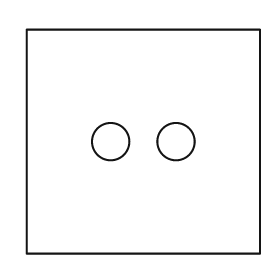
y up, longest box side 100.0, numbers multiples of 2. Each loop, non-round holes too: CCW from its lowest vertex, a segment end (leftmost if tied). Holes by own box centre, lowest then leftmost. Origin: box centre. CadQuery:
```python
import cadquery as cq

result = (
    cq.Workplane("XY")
    .moveTo(-50.0, -48.0)
    .lineTo(50.0, -48.0)
    .lineTo(50.0, 48.0)
    .lineTo(-50.0, 48.0)
    .close()
    .moveTo(-14.0, 0.0)
    .circle(8.0)
    .moveTo(14.0, 0.0)
    .circle(8.0)
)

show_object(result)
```